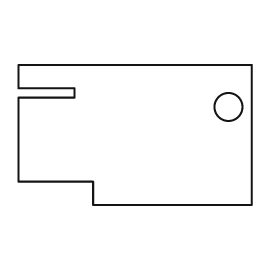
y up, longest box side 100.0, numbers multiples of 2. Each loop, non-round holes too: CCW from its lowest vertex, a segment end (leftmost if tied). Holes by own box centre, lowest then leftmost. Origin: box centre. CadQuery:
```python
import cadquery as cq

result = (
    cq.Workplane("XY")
    .moveTo(-18.0, -30.0)
    .lineTo(50.0, -30.0)
    .lineTo(50.0, 30.0)
    .lineTo(-50.0, 30.0)
    .lineTo(-50.0, 20.0)
    .lineTo(-26.0, 20.0)
    .lineTo(-26.0, 16.0)
    .lineTo(-50.0, 16.0)
    .lineTo(-50.0, -20.0)
    .lineTo(-18.0, -20.0)
    .close()
    .moveTo(40.0, 12.0)
    .circle(6.0)
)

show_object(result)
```